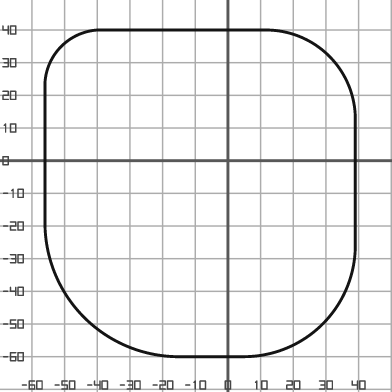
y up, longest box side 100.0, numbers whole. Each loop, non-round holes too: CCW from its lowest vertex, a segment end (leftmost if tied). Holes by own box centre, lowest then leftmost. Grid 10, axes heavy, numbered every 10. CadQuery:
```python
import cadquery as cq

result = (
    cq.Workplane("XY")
    .moveTo(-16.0, -60.0)
    .lineTo(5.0, -60.0)
    .threePointArc((29.0, -50.0), (39.0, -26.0))
    .lineTo(39.0, 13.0)
    .threePointArc((31.0, 32.0), (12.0, 40.0))
    .lineTo(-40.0, 40.0)
    .threePointArc((-51.0, 35.0), (-56.0, 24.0))
    .lineTo(-56.0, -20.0)
    .threePointArc((-44.0, -48.0), (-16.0, -60.0))
    .close()
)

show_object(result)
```